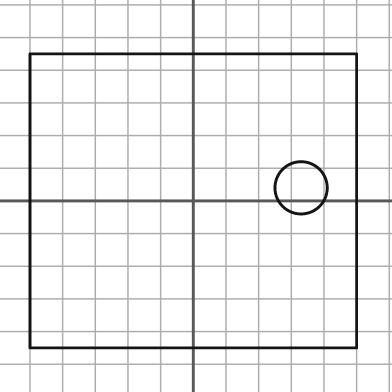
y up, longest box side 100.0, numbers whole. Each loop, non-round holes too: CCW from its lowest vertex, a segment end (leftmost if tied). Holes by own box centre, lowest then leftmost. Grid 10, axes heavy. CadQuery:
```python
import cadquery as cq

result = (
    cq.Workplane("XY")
    .moveTo(-50.0, -45.0)
    .lineTo(50.0, -45.0)
    .lineTo(50.0, 45.0)
    .lineTo(-50.0, 45.0)
    .close()
    .moveTo(33.0, 4.0)
    .circle(8.0)
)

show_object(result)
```